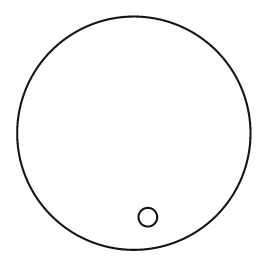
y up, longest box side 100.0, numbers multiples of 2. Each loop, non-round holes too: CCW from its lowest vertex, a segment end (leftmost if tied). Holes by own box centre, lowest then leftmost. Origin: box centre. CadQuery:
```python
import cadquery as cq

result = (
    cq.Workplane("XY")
    .moveTo(0.0, 0.0)
    .circle(50.0)
    .moveTo(6.0, -36.0)
    .circle(4.0)
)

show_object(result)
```